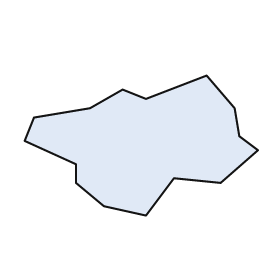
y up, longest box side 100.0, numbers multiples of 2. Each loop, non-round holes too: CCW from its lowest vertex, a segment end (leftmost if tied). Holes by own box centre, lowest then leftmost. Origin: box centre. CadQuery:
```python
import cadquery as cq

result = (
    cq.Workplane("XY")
    .moveTo(2.0, -30.0)
    .lineTo(14.0, -14.0)
    .lineTo(34.0, -16.0)
    .lineTo(50.0, -2.0)
    .lineTo(42.0, 4.0)
    .lineTo(40.0, 16.0)
    .lineTo(28.0, 30.0)
    .lineTo(2.0, 20.0)
    .lineTo(-8.0, 24.0)
    .lineTo(-22.0, 16.0)
    .lineTo(-46.0, 12.0)
    .lineTo(-50.0, 2.0)
    .lineTo(-28.0, -8.0)
    .lineTo(-28.0, -16.0)
    .lineTo(-16.0, -26.0)
    .close()
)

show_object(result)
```